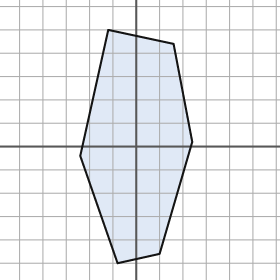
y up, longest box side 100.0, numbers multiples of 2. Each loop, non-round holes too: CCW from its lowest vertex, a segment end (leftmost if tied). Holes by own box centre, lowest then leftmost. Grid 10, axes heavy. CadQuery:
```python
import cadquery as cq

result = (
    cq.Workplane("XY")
    .moveTo(-8.0, -50.0)
    .lineTo(10.0, -46.0)
    .lineTo(24.0, 2.0)
    .lineTo(16.0, 44.0)
    .lineTo(-12.0, 50.0)
    .lineTo(-24.0, -4.0)
    .close()
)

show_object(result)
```